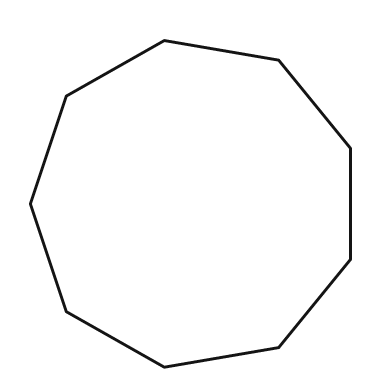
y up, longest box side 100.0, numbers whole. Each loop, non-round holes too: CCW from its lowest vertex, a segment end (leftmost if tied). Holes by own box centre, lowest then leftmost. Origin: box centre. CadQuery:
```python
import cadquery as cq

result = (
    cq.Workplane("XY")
    .moveTo(-8.0, -50.0)
    .lineTo(27.0, -44.0)
    .lineTo(49.0, -17.0)
    .lineTo(49.0, 17.0)
    .lineTo(27.0, 44.0)
    .lineTo(-8.0, 50.0)
    .lineTo(-38.0, 33.0)
    .lineTo(-49.0, 0.0)
    .lineTo(-38.0, -33.0)
    .close()
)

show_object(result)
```